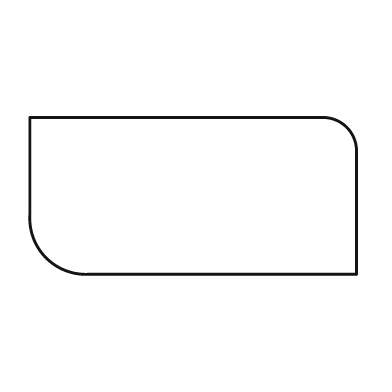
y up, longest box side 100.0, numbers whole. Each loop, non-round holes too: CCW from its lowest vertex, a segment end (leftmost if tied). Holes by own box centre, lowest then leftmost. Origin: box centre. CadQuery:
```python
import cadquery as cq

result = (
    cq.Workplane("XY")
    .moveTo(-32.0, -24.0)
    .lineTo(50.0, -24.0)
    .lineTo(50.0, 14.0)
    .threePointArc((47.0, 21.0), (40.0, 24.0))
    .lineTo(-50.0, 24.0)
    .lineTo(-50.0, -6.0)
    .threePointArc((-45.0, -19.0), (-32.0, -24.0))
    .close()
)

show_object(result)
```